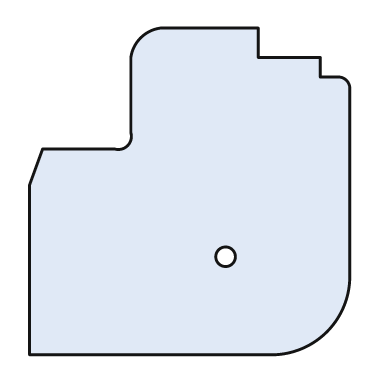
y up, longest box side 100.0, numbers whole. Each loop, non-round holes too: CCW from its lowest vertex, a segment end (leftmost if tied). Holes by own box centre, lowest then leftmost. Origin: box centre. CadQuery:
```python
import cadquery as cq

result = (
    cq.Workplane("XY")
    .moveTo(-49.0, -50.0)
    .lineTo(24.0, -50.0)
    .threePointArc((42.0, -43.0), (49.0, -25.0))
    .lineTo(49.0, 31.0)
    .threePointArc((48.0, 34.0), (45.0, 35.0))
    .lineTo(40.0, 35.0)
    .lineTo(40.0, 41.0)
    .lineTo(21.0, 41.0)
    .lineTo(21.0, 50.0)
    .lineTo(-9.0, 50.0)
    .threePointArc((-15.0, 47.0), (-18.0, 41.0))
    .lineTo(-18.0, 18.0)
    .threePointArc((-19.0, 14.0), (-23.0, 13.0))
    .lineTo(-45.0, 13.0)
    .lineTo(-49.0, 2.0)
    .close()
    .moveTo(11.0, -20.0)
    .circle(3.0)
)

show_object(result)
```